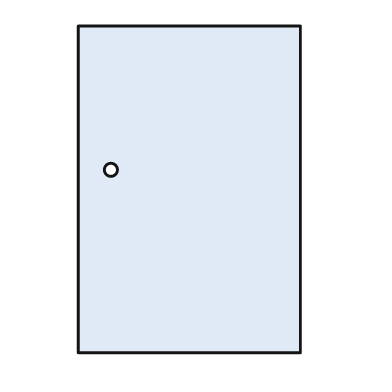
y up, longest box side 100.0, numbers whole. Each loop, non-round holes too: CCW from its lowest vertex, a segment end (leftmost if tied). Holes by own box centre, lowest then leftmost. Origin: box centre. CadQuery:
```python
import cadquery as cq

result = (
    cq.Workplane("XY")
    .moveTo(-34.0, -50.0)
    .lineTo(34.0, -50.0)
    .lineTo(34.0, 50.0)
    .lineTo(-34.0, 50.0)
    .close()
    .moveTo(-24.0, 6.0)
    .circle(2.0)
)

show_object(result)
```